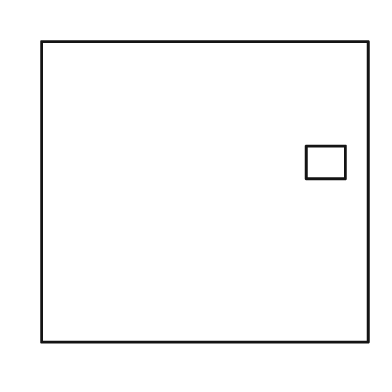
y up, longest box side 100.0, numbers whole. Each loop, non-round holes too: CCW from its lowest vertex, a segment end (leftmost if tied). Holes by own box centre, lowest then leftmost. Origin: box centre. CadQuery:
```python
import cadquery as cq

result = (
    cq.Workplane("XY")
    .moveTo(-50.0, -46.0)
    .lineTo(50.0, -46.0)
    .lineTo(50.0, 46.0)
    .lineTo(-50.0, 46.0)
    .close()
    .moveTo(31.0, 4.0)
    .lineTo(43.0, 4.0)
    .lineTo(43.0, 14.0)
    .lineTo(31.0, 14.0)
    .close()
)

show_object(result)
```